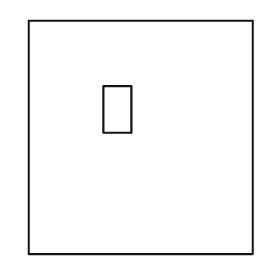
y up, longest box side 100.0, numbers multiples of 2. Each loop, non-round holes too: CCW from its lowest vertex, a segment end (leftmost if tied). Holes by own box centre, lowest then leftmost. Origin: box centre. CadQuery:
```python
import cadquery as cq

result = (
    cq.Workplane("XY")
    .moveTo(-48.0, -50.0)
    .lineTo(48.0, -50.0)
    .lineTo(48.0, 50.0)
    .lineTo(-48.0, 50.0)
    .close()
    .moveTo(-16.0, 2.0)
    .lineTo(-4.0, 2.0)
    .lineTo(-4.0, 22.0)
    .lineTo(-16.0, 22.0)
    .close()
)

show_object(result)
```